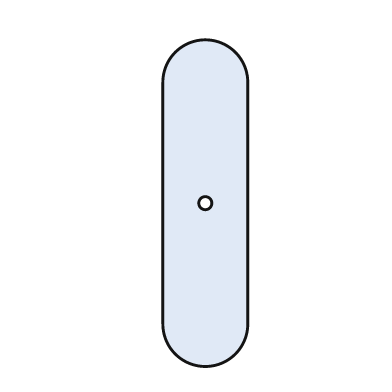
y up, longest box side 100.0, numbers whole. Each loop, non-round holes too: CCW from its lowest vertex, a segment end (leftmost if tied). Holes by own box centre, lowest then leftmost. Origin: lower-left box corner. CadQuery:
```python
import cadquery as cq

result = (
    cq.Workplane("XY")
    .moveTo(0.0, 13.0)
    .threePointArc((13.0, 0.0), (26.0, 13.0))
    .lineTo(26.0, 87.0)
    .threePointArc((13.0, 100.0), (0.0, 87.0))
    .close()
    .moveTo(13.0, 50.0)
    .circle(2.0)
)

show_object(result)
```